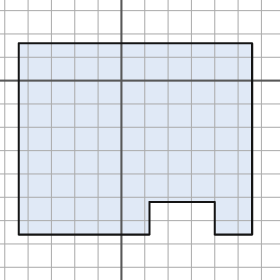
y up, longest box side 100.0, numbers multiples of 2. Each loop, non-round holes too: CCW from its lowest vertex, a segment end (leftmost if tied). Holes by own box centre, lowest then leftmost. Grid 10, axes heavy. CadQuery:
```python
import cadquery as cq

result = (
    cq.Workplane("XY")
    .moveTo(-44.0, -66.0)
    .lineTo(12.0, -66.0)
    .lineTo(12.0, -52.0)
    .lineTo(40.0, -52.0)
    .lineTo(40.0, -66.0)
    .lineTo(56.0, -66.0)
    .lineTo(56.0, 16.0)
    .lineTo(-44.0, 16.0)
    .close()
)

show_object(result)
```